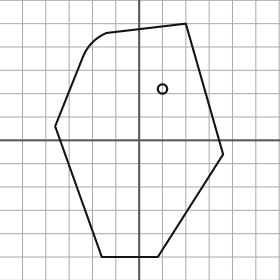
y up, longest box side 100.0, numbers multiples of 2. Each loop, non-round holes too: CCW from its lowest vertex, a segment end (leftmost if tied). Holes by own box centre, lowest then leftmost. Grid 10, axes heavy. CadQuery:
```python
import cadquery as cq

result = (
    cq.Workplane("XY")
    .moveTo(-16.0, -50.0)
    .lineTo(8.0, -50.0)
    .lineTo(36.0, -6.0)
    .lineTo(20.0, 50.0)
    .lineTo(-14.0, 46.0)
    .threePointArc((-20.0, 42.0), (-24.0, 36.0))
    .lineTo(-36.0, 6.0)
    .close()
    .moveTo(10.0, 22.0)
    .circle(2.0)
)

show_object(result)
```